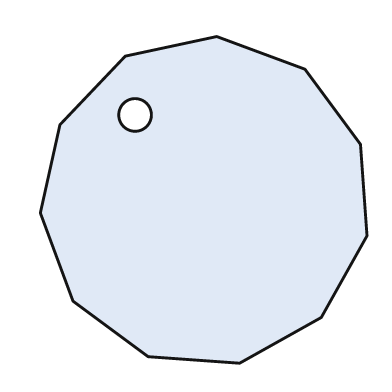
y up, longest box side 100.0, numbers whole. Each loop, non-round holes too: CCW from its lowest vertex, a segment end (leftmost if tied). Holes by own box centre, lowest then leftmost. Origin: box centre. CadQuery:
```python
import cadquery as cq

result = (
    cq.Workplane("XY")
    .moveTo(11.0, -50.0)
    .lineTo(36.0, -36.0)
    .lineTo(50.0, -11.0)
    .lineTo(48.0, 17.0)
    .lineTo(31.0, 40.0)
    .lineTo(4.0, 50.0)
    .lineTo(-24.0, 44.0)
    .lineTo(-44.0, 23.0)
    .lineTo(-50.0, -4.0)
    .lineTo(-40.0, -31.0)
    .lineTo(-17.0, -48.0)
    .close()
    .moveTo(-21.0, 26.0)
    .circle(5.0)
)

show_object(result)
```